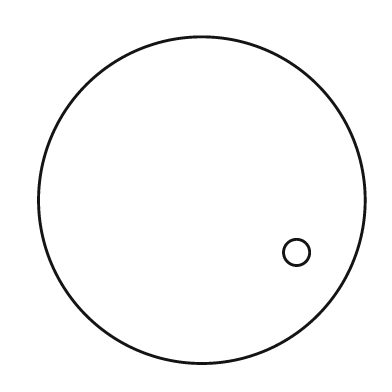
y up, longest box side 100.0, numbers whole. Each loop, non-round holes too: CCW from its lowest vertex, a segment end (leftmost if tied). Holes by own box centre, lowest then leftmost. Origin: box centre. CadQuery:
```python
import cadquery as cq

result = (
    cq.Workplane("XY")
    .moveTo(0.0, 0.0)
    .circle(50.0)
    .moveTo(29.0, -16.0)
    .circle(4.0)
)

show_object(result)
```